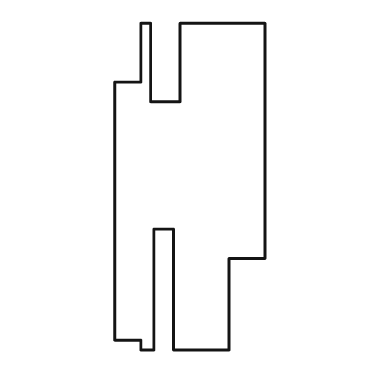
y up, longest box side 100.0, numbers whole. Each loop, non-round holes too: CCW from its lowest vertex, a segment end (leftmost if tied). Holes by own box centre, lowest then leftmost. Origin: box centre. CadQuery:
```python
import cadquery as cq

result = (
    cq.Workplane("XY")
    .moveTo(-15.0, -50.0)
    .lineTo(-11.0, -50.0)
    .lineTo(-11.0, -13.0)
    .lineTo(-5.0, -13.0)
    .lineTo(-5.0, -50.0)
    .lineTo(12.0, -50.0)
    .lineTo(12.0, -22.0)
    .lineTo(23.0, -22.0)
    .lineTo(23.0, 50.0)
    .lineTo(-3.0, 50.0)
    .lineTo(-3.0, 26.0)
    .lineTo(-12.0, 26.0)
    .lineTo(-12.0, 50.0)
    .lineTo(-15.0, 50.0)
    .lineTo(-15.0, 32.0)
    .lineTo(-23.0, 32.0)
    .lineTo(-23.0, -47.0)
    .lineTo(-15.0, -47.0)
    .close()
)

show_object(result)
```